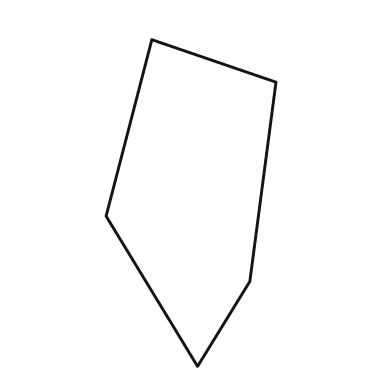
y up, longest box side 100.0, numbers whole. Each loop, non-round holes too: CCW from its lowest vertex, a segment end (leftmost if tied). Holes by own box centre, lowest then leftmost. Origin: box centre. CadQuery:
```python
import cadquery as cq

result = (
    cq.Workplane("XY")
    .moveTo(2.0, -50.0)
    .lineTo(18.0, -24.0)
    .lineTo(26.0, 37.0)
    .lineTo(-12.0, 50.0)
    .lineTo(-26.0, -4.0)
    .close()
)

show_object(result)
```